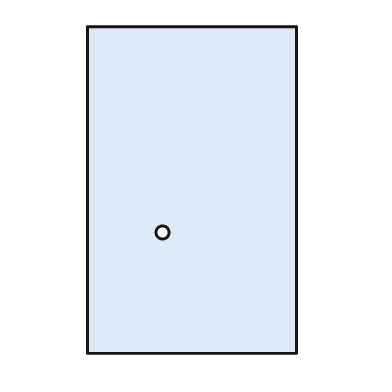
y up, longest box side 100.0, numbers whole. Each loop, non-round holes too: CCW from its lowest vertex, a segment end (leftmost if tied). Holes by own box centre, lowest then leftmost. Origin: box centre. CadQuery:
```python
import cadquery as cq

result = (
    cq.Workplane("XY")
    .moveTo(-32.0, -50.0)
    .lineTo(32.0, -50.0)
    .lineTo(32.0, 50.0)
    .lineTo(-32.0, 50.0)
    .close()
    .moveTo(-9.0, -13.0)
    .circle(2.0)
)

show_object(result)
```